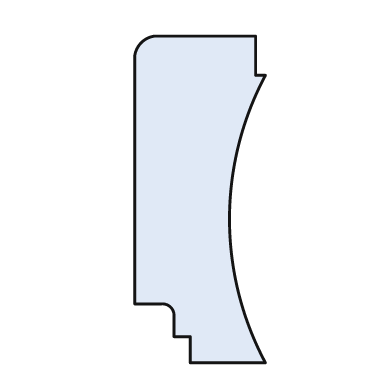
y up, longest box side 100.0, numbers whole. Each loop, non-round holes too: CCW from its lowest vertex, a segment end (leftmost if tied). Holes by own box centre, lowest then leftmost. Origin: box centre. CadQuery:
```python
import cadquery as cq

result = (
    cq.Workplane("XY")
    .moveTo(-3.0, -50.0)
    .lineTo(20.0, -50.0)
    .threePointArc((9.0, -6.0), (20.0, 38.0))
    .lineTo(17.0, 38.0)
    .lineTo(17.0, 50.0)
    .lineTo(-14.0, 50.0)
    .threePointArc((-18.0, 48.0), (-20.0, 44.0))
    .lineTo(-20.0, -32.0)
    .lineTo(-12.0, -32.0)
    .threePointArc((-9.0, -33.0), (-8.0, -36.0))
    .lineTo(-8.0, -42.0)
    .lineTo(-3.0, -42.0)
    .close()
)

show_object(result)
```